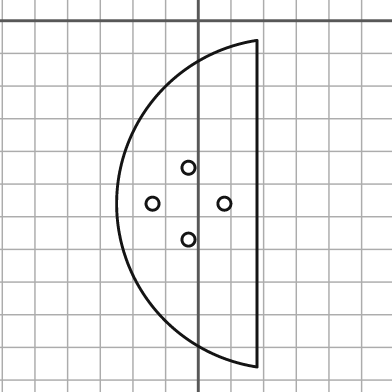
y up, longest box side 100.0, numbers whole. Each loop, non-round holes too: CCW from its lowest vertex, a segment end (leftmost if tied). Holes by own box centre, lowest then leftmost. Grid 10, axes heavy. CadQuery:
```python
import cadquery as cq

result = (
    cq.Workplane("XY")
    .moveTo(18.0, -106.0)
    .lineTo(18.0, -6.0)
    .threePointArc((-25.0, -56.0), (18.0, -106.0))
    .close()
    .moveTo(-3.0, -67.0)
    .circle(2.0)
    .moveTo(-14.0, -56.0)
    .circle(2.0)
    .moveTo(8.0, -56.0)
    .circle(2.0)
    .moveTo(-3.0, -45.0)
    .circle(2.0)
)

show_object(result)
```